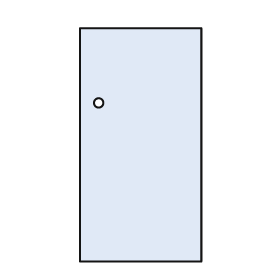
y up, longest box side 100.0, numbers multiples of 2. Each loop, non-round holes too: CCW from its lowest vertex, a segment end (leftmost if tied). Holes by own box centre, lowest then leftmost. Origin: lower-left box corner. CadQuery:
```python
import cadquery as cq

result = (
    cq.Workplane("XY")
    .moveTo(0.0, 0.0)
    .lineTo(52.0, 0.0)
    .lineTo(52.0, 100.0)
    .lineTo(0.0, 100.0)
    .close()
    .moveTo(8.0, 68.0)
    .circle(2.0)
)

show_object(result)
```